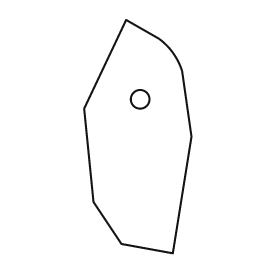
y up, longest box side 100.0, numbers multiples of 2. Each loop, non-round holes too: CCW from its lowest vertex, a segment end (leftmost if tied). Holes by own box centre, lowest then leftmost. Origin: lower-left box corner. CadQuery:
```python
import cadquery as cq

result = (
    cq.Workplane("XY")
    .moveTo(38.0, 0.0)
    .lineTo(46.0, 50.0)
    .lineTo(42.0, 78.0)
    .threePointArc((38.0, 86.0), (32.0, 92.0))
    .lineTo(18.0, 100.0)
    .lineTo(0.0, 62.0)
    .lineTo(4.0, 22.0)
    .lineTo(16.0, 4.0)
    .close()
    .moveTo(24.0, 66.0)
    .circle(4.0)
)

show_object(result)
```